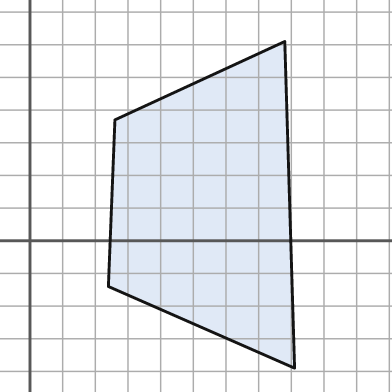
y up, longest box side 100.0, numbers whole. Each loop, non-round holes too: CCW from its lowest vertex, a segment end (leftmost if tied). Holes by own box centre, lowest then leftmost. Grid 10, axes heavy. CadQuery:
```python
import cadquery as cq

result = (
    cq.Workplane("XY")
    .moveTo(81.0, -39.0)
    .lineTo(78.0, 61.0)
    .lineTo(26.0, 37.0)
    .lineTo(24.0, -14.0)
    .close()
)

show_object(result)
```